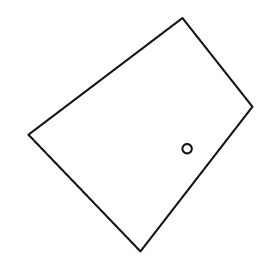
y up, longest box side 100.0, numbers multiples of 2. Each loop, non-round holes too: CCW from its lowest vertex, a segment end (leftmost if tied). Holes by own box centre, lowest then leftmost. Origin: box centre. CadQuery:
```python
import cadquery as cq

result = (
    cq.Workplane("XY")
    .moveTo(0.0, -50.0)
    .lineTo(48.0, 12.0)
    .lineTo(18.0, 50.0)
    .lineTo(-48.0, 0.0)
    .close()
    .moveTo(20.0, -6.0)
    .circle(2.0)
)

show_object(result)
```